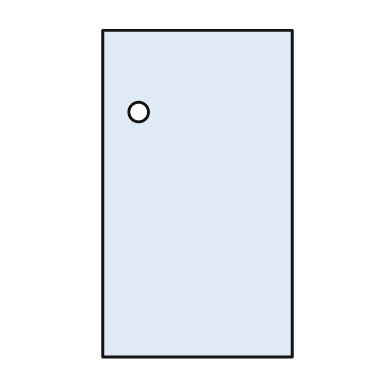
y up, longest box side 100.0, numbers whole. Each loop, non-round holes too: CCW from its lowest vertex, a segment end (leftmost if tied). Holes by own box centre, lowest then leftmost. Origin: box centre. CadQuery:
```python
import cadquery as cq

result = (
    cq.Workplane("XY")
    .moveTo(-29.0, -50.0)
    .lineTo(29.0, -50.0)
    .lineTo(29.0, 50.0)
    .lineTo(-29.0, 50.0)
    .close()
    .moveTo(-18.0, 25.0)
    .circle(3.0)
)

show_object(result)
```